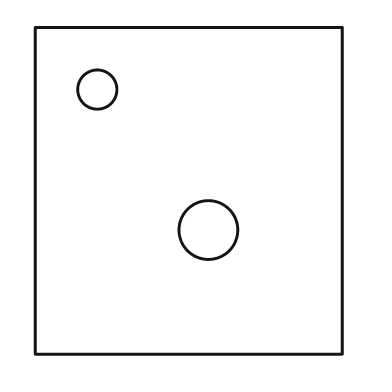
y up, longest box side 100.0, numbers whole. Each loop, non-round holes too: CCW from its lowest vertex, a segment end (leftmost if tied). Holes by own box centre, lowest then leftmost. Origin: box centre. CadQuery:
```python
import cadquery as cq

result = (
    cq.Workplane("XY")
    .moveTo(-47.0, -50.0)
    .lineTo(47.0, -50.0)
    .lineTo(47.0, 50.0)
    .lineTo(-47.0, 50.0)
    .close()
    .moveTo(6.0, -12.0)
    .circle(9.0)
    .moveTo(-28.0, 31.0)
    .circle(6.0)
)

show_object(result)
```